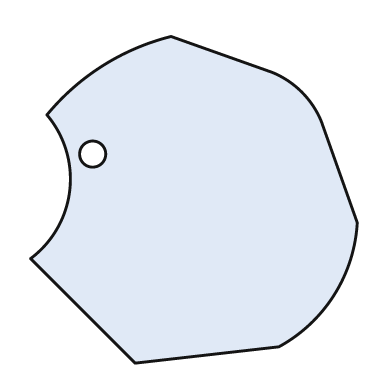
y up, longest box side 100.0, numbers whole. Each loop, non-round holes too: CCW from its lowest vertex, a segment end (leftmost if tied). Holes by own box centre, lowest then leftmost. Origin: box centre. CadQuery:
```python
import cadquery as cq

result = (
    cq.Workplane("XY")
    .moveTo(-18.0, -50.0)
    .lineTo(26.0, -45.0)
    .threePointArc((43.0, -29.0), (50.0, -7.0))
    .lineTo(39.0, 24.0)
    .threePointArc((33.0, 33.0), (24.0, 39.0))
    .lineTo(-7.0, 50.0)
    .threePointArc((-28.0, 41.0), (-45.0, 26.0))
    .threePointArc((-38.0, 3.0), (-50.0, -18.0))
    .close()
    .moveTo(-31.0, 14.0)
    .circle(4.0)
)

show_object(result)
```